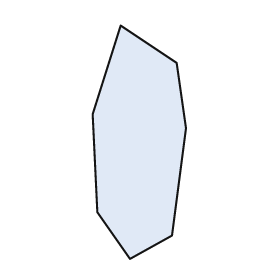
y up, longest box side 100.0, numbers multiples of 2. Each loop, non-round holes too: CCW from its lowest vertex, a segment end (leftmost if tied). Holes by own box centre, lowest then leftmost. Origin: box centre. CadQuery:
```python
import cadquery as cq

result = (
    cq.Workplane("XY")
    .moveTo(-4.0, -50.0)
    .lineTo(14.0, -40.0)
    .lineTo(20.0, 6.0)
    .lineTo(16.0, 34.0)
    .lineTo(-8.0, 50.0)
    .lineTo(-20.0, 12.0)
    .lineTo(-18.0, -30.0)
    .close()
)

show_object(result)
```